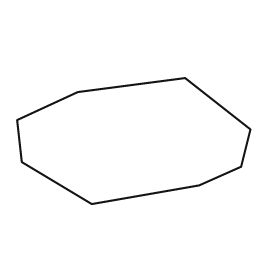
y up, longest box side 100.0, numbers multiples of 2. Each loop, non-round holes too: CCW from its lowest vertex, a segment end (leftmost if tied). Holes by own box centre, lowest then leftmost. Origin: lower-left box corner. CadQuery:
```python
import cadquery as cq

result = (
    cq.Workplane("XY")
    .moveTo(32.0, 0.0)
    .lineTo(78.0, 8.0)
    .lineTo(96.0, 16.0)
    .lineTo(100.0, 32.0)
    .lineTo(72.0, 54.0)
    .lineTo(26.0, 48.0)
    .lineTo(0.0, 36.0)
    .lineTo(2.0, 18.0)
    .close()
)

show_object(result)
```